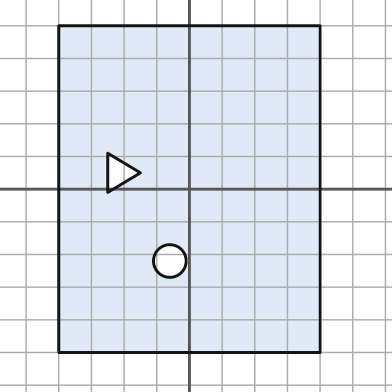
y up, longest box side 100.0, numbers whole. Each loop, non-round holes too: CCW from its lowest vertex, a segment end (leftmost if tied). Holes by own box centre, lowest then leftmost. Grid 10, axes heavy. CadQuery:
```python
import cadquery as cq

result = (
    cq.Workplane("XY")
    .moveTo(-40.0, -50.0)
    .lineTo(40.0, -50.0)
    .lineTo(40.0, 50.0)
    .lineTo(-40.0, 50.0)
    .close()
    .moveTo(-6.0, -22.0)
    .circle(5.0)
    .moveTo(-25.0, -1.0)
    .lineTo(-15.0, 5.0)
    .lineTo(-25.0, 11.0)
    .close()
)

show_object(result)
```